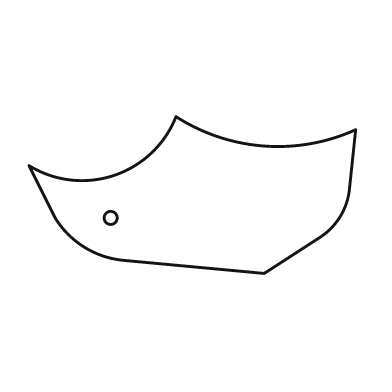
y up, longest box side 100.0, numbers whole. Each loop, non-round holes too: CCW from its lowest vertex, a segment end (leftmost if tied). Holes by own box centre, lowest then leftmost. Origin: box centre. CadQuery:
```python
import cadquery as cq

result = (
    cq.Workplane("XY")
    .moveTo(22.0, -24.0)
    .lineTo(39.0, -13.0)
    .threePointArc((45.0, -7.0), (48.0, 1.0))
    .lineTo(50.0, 20.0)
    .threePointArc((22.0, 15.0), (-5.0, 24.0))
    .threePointArc((-24.0, 6.0), (-50.0, 9.0))
    .lineTo(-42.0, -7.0)
    .threePointArc((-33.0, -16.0), (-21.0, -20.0))
    .close()
    .moveTo(-25.0, -7.0)
    .circle(2.0)
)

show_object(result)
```